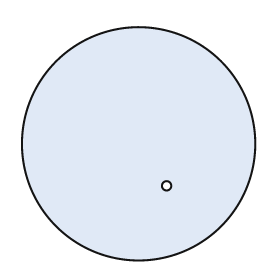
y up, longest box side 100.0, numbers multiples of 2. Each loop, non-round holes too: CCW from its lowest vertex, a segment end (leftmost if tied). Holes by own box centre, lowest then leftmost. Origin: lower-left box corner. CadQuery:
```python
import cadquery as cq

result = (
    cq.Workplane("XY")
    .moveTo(50.0, 50.0)
    .circle(50.0)
    .moveTo(62.0, 32.0)
    .circle(2.0)
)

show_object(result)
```